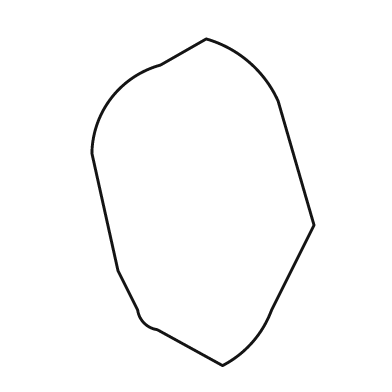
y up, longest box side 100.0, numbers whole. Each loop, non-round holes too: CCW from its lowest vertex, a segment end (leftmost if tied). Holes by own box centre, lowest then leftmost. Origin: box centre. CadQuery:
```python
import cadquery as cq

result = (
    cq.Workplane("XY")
    .moveTo(6.0, -50.0)
    .threePointArc((15.0, -43.0), (21.0, -33.0))
    .lineTo(34.0, -7.0)
    .lineTo(23.0, 31.0)
    .threePointArc((14.0, 43.0), (1.0, 50.0))
    .lineTo(-13.0, 42.0)
    .threePointArc((-28.0, 32.0), (-34.0, 15.0))
    .lineTo(-26.0, -21.0)
    .lineTo(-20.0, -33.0)
    .threePointArc((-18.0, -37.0), (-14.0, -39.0))
    .close()
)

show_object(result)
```